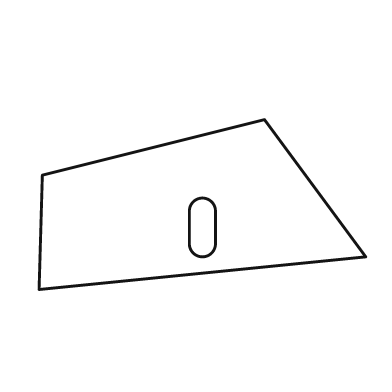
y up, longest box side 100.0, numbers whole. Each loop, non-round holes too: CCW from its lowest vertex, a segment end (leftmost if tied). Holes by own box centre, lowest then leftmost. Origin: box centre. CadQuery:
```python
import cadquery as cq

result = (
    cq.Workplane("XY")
    .moveTo(-50.0, -26.0)
    .lineTo(50.0, -16.0)
    .lineTo(19.0, 26.0)
    .lineTo(-49.0, 9.0)
    .close()
    .moveTo(-4.0, -12.0)
    .threePointArc((0.0, -16.0), (4.0, -12.0))
    .lineTo(4.0, -2.0)
    .threePointArc((0.0, 2.0), (-4.0, -2.0))
    .close()
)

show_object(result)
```